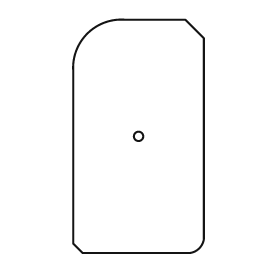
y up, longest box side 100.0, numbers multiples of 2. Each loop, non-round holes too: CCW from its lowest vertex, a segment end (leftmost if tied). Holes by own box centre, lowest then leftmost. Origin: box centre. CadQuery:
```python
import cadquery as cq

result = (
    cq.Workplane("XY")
    .moveTo(-24.0, -50.0)
    .lineTo(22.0, -50.0)
    .threePointArc((26.0, -48.0), (28.0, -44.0))
    .lineTo(28.0, 42.0)
    .lineTo(20.0, 50.0)
    .lineTo(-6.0, 50.0)
    .threePointArc((-22.0, 44.0), (-28.0, 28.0))
    .lineTo(-28.0, -46.0)
    .close()
    .moveTo(0.0, 0.0)
    .circle(2.0)
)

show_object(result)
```